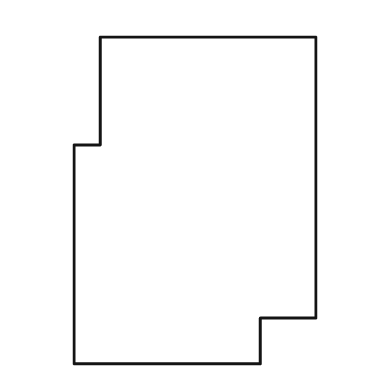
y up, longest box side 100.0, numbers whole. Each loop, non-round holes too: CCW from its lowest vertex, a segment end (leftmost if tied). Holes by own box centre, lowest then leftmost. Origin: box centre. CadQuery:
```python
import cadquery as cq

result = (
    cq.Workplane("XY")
    .moveTo(-37.0, -50.0)
    .lineTo(20.0, -50.0)
    .lineTo(20.0, -36.0)
    .lineTo(37.0, -36.0)
    .lineTo(37.0, 50.0)
    .lineTo(-29.0, 50.0)
    .lineTo(-29.0, 17.0)
    .lineTo(-37.0, 17.0)
    .close()
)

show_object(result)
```